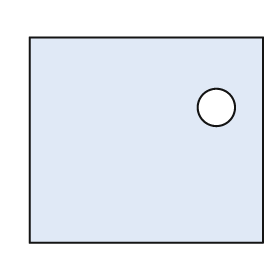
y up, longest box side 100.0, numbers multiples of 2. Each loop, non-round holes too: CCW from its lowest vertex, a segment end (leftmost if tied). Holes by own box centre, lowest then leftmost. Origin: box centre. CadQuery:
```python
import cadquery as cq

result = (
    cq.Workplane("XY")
    .moveTo(-50.0, -44.0)
    .lineTo(50.0, -44.0)
    .lineTo(50.0, 44.0)
    .lineTo(-50.0, 44.0)
    .close()
    .moveTo(30.0, 14.0)
    .circle(8.0)
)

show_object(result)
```